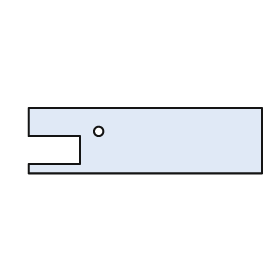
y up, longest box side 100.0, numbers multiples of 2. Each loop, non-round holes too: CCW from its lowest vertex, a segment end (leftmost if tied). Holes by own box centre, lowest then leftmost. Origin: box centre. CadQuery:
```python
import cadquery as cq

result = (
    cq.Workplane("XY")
    .moveTo(-50.0, -14.0)
    .lineTo(50.0, -14.0)
    .lineTo(50.0, 14.0)
    .lineTo(-50.0, 14.0)
    .lineTo(-50.0, 2.0)
    .lineTo(-28.0, 2.0)
    .lineTo(-28.0, -10.0)
    .lineTo(-50.0, -10.0)
    .close()
    .moveTo(-20.0, 4.0)
    .circle(2.0)
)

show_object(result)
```